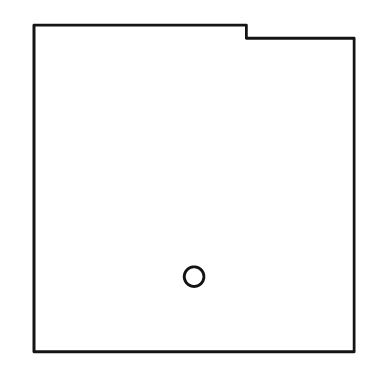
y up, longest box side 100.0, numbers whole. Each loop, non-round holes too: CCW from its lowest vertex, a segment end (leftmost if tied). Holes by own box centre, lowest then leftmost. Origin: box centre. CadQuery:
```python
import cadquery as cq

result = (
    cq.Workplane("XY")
    .moveTo(-49.0, -50.0)
    .lineTo(49.0, -50.0)
    .lineTo(49.0, 46.0)
    .lineTo(16.0, 46.0)
    .lineTo(16.0, 50.0)
    .lineTo(-49.0, 50.0)
    .close()
    .moveTo(0.0, -27.0)
    .circle(3.0)
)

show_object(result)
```